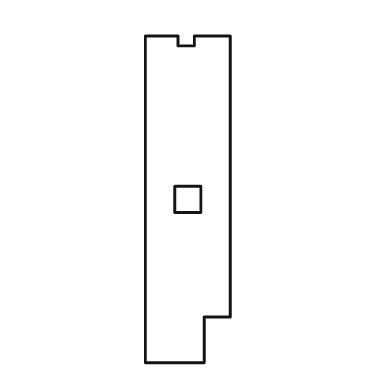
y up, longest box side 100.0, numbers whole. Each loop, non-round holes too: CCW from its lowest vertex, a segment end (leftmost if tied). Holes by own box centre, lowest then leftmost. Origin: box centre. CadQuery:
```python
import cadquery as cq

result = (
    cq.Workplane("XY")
    .moveTo(-13.0, -50.0)
    .lineTo(5.0, -50.0)
    .lineTo(5.0, -36.0)
    .lineTo(13.0, -36.0)
    .lineTo(13.0, 50.0)
    .lineTo(2.0, 50.0)
    .lineTo(2.0, 47.0)
    .lineTo(-3.0, 47.0)
    .lineTo(-3.0, 50.0)
    .lineTo(-13.0, 50.0)
    .close()
    .moveTo(-4.0, -4.0)
    .lineTo(4.0, -4.0)
    .lineTo(4.0, 4.0)
    .lineTo(-4.0, 4.0)
    .close()
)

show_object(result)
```